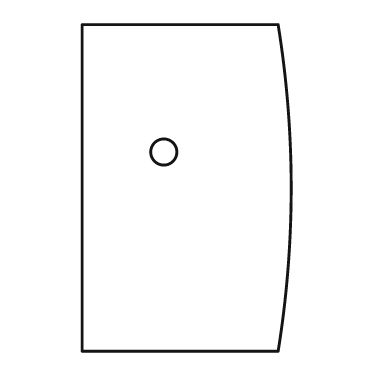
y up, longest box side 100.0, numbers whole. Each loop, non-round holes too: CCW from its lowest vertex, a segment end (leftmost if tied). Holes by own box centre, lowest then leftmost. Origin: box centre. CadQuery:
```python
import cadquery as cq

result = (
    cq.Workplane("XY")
    .moveTo(-32.0, -50.0)
    .lineTo(28.0, -50.0)
    .threePointArc((32.0, 0.0), (28.0, 50.0))
    .lineTo(-32.0, 50.0)
    .close()
    .moveTo(-7.0, 11.0)
    .circle(4.0)
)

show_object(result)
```